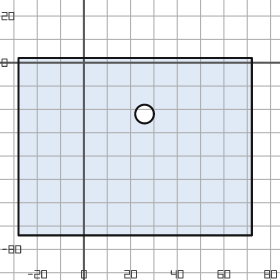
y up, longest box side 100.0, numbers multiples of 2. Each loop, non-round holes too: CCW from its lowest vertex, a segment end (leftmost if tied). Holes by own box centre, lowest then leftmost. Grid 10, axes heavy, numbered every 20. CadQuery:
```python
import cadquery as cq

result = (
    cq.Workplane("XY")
    .moveTo(-28.0, -74.0)
    .lineTo(72.0, -74.0)
    .lineTo(72.0, 2.0)
    .lineTo(-28.0, 2.0)
    .close()
    .moveTo(26.0, -22.0)
    .circle(4.0)
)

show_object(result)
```